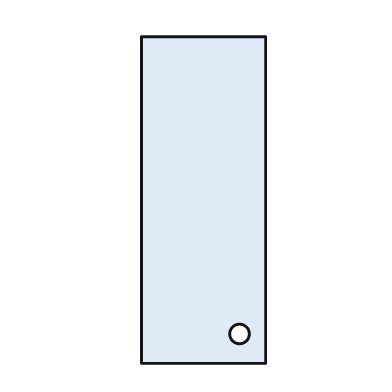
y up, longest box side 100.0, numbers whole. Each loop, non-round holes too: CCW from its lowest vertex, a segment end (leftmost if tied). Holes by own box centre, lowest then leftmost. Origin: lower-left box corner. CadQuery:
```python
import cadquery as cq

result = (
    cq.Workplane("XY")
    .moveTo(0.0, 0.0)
    .lineTo(38.0, 0.0)
    .lineTo(38.0, 100.0)
    .lineTo(0.0, 100.0)
    .close()
    .moveTo(30.0, 9.0)
    .circle(3.0)
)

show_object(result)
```